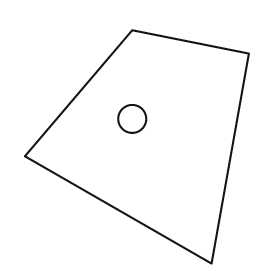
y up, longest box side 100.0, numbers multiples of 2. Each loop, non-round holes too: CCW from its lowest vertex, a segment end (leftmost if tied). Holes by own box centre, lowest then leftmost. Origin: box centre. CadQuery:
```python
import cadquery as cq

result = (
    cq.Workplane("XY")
    .moveTo(32.0, -50.0)
    .lineTo(48.0, 40.0)
    .lineTo(-2.0, 50.0)
    .lineTo(-48.0, -4.0)
    .close()
    .moveTo(-2.0, 12.0)
    .circle(6.0)
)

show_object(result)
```